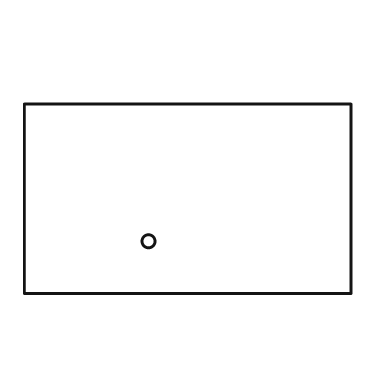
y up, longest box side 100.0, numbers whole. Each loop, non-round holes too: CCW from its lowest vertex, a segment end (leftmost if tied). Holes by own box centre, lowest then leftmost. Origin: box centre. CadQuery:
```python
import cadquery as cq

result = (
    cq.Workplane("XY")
    .moveTo(-50.0, -29.0)
    .lineTo(50.0, -29.0)
    .lineTo(50.0, 29.0)
    .lineTo(-50.0, 29.0)
    .close()
    .moveTo(-12.0, -13.0)
    .circle(2.0)
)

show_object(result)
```